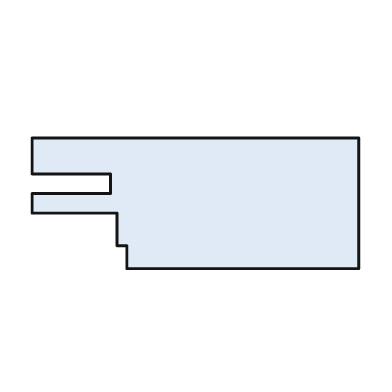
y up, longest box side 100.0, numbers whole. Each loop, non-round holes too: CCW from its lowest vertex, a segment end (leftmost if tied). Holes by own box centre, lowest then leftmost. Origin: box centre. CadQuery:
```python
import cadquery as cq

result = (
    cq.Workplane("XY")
    .moveTo(-21.0, -20.0)
    .lineTo(50.0, -20.0)
    .lineTo(50.0, 20.0)
    .lineTo(-50.0, 20.0)
    .lineTo(-50.0, 9.0)
    .lineTo(-26.0, 9.0)
    .lineTo(-26.0, 3.0)
    .lineTo(-50.0, 3.0)
    .lineTo(-50.0, -3.0)
    .lineTo(-24.0, -3.0)
    .lineTo(-24.0, -13.0)
    .lineTo(-21.0, -13.0)
    .close()
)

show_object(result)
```